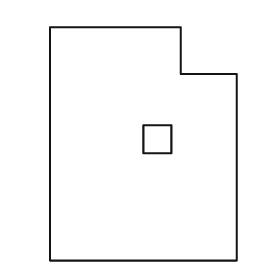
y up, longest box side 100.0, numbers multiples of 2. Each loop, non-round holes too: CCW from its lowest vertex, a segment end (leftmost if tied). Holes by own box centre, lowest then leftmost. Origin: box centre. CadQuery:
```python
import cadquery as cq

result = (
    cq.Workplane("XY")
    .moveTo(-40.0, -50.0)
    .lineTo(40.0, -50.0)
    .lineTo(40.0, 30.0)
    .lineTo(16.0, 30.0)
    .lineTo(16.0, 50.0)
    .lineTo(-40.0, 50.0)
    .close()
    .moveTo(0.0, -4.0)
    .lineTo(12.0, -4.0)
    .lineTo(12.0, 8.0)
    .lineTo(0.0, 8.0)
    .close()
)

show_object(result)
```